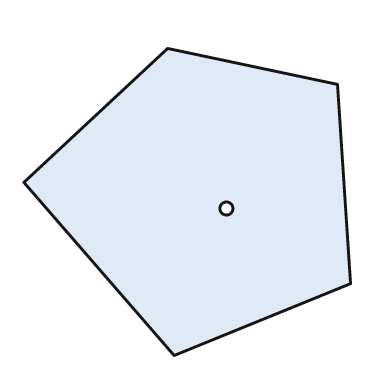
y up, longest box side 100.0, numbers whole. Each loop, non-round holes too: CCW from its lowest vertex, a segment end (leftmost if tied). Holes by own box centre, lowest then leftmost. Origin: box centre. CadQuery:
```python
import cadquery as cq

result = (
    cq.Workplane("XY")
    .moveTo(-4.0, -47.0)
    .lineTo(50.0, -25.0)
    .lineTo(46.0, 36.0)
    .lineTo(-6.0, 47.0)
    .lineTo(-50.0, 6.0)
    .close()
    .moveTo(12.0, -2.0)
    .circle(2.0)
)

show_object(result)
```